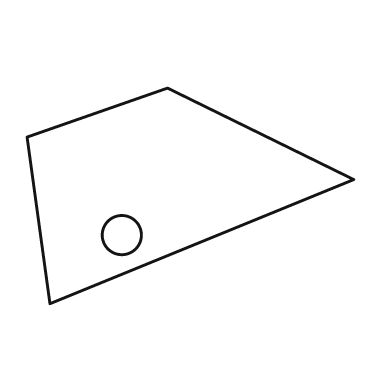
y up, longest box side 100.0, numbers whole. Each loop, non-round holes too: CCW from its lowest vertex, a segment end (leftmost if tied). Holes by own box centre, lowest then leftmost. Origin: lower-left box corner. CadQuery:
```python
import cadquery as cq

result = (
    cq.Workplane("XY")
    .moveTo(7.0, 0.0)
    .lineTo(100.0, 38.0)
    .lineTo(43.0, 66.0)
    .lineTo(0.0, 51.0)
    .close()
    .moveTo(29.0, 21.0)
    .circle(6.0)
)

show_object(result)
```